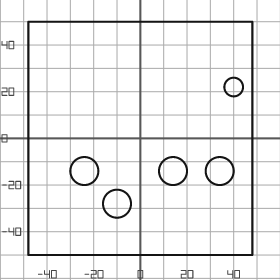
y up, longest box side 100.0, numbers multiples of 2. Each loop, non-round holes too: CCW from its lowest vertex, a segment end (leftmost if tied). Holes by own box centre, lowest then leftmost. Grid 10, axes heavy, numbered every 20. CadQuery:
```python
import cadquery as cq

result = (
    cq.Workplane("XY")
    .moveTo(-48.0, -50.0)
    .lineTo(48.0, -50.0)
    .lineTo(48.0, 50.0)
    .lineTo(-48.0, 50.0)
    .close()
    .moveTo(-10.0, -28.0)
    .circle(6.0)
    .moveTo(-24.0, -14.0)
    .circle(6.0)
    .moveTo(14.0, -14.0)
    .circle(6.0)
    .moveTo(34.0, -14.0)
    .circle(6.0)
    .moveTo(40.0, 22.0)
    .circle(4.0)
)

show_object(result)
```